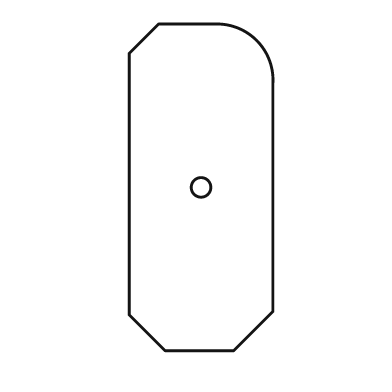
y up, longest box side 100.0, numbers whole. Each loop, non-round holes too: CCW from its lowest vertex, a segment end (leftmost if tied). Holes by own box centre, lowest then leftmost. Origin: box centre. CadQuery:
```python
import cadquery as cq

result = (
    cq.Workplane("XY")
    .moveTo(-11.0, -50.0)
    .lineTo(10.0, -50.0)
    .lineTo(22.0, -38.0)
    .lineTo(22.0, 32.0)
    .threePointArc((17.0, 45.0), (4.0, 50.0))
    .lineTo(-13.0, 50.0)
    .lineTo(-22.0, 41.0)
    .lineTo(-22.0, -39.0)
    .close()
    .moveTo(0.0, 0.0)
    .circle(3.0)
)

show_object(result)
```